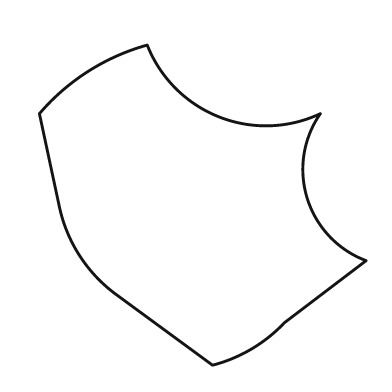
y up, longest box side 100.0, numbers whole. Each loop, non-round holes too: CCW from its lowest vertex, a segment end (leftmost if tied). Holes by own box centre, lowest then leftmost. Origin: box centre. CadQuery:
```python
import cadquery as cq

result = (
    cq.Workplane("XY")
    .moveTo(3.0, -49.0)
    .threePointArc((15.0, -44.0), (25.0, -36.0))
    .lineTo(50.0, -17.0)
    .threePointArc((32.0, 2.0), (36.0, 28.0))
    .threePointArc((5.0, 27.0), (-17.0, 49.0))
    .threePointArc((-35.0, 41.0), (-50.0, 28.0))
    .lineTo(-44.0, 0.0)
    .threePointArc((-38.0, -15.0), (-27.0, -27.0))
    .close()
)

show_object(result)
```